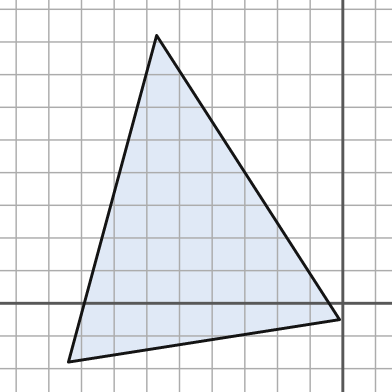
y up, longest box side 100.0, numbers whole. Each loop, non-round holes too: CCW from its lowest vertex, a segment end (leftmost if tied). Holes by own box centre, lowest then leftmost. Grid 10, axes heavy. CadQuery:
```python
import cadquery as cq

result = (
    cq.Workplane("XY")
    .moveTo(-84.0, -18.0)
    .lineTo(-1.0, -5.0)
    .lineTo(-57.0, 82.0)
    .close()
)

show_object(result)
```